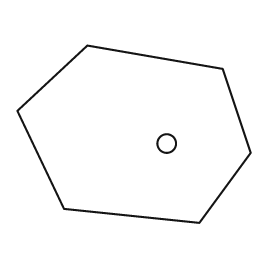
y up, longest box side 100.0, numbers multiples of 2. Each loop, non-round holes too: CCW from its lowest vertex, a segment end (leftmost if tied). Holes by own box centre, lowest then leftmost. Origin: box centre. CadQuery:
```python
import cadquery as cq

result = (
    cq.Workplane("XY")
    .moveTo(28.0, -38.0)
    .lineTo(50.0, -8.0)
    .lineTo(38.0, 28.0)
    .lineTo(-20.0, 38.0)
    .lineTo(-50.0, 10.0)
    .lineTo(-30.0, -32.0)
    .close()
    .moveTo(14.0, -4.0)
    .circle(4.0)
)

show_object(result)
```